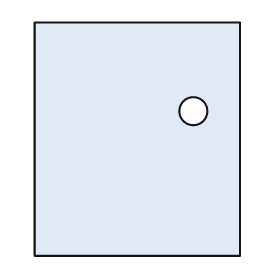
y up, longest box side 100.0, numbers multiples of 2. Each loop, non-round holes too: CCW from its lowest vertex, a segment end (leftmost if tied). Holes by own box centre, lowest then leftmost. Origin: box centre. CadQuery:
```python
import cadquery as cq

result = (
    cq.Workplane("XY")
    .moveTo(-44.0, -50.0)
    .lineTo(44.0, -50.0)
    .lineTo(44.0, 50.0)
    .lineTo(-44.0, 50.0)
    .close()
    .moveTo(24.0, 12.0)
    .circle(6.0)
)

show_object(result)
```